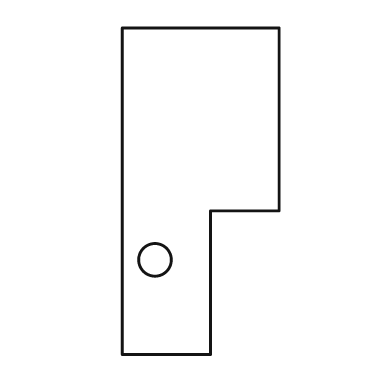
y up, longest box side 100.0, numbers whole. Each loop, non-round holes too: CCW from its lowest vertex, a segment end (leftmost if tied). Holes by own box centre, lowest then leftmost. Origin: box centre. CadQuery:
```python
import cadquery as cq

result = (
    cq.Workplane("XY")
    .moveTo(-24.0, -50.0)
    .lineTo(3.0, -50.0)
    .lineTo(3.0, -6.0)
    .lineTo(24.0, -6.0)
    .lineTo(24.0, 50.0)
    .lineTo(-24.0, 50.0)
    .close()
    .moveTo(-14.0, -21.0)
    .circle(5.0)
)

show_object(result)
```